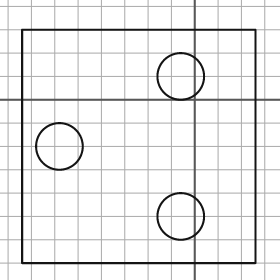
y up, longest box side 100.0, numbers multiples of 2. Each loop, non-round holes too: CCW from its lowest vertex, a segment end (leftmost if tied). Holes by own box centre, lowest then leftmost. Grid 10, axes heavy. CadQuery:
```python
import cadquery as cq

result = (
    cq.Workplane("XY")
    .moveTo(-74.0, -70.0)
    .lineTo(26.0, -70.0)
    .lineTo(26.0, 30.0)
    .lineTo(-74.0, 30.0)
    .close()
    .moveTo(-6.0, -50.0)
    .circle(10.0)
    .moveTo(-58.0, -20.0)
    .circle(10.0)
    .moveTo(-6.0, 10.0)
    .circle(10.0)
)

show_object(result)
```